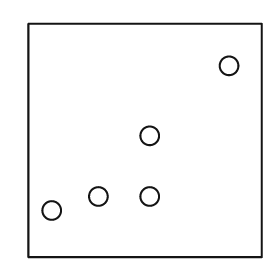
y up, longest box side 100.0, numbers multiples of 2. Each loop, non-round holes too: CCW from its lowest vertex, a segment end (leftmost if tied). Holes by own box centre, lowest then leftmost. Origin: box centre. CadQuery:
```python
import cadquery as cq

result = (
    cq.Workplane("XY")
    .moveTo(-50.0, -50.0)
    .lineTo(50.0, -50.0)
    .lineTo(50.0, 50.0)
    .lineTo(-50.0, 50.0)
    .close()
    .moveTo(-40.0, -30.0)
    .circle(4.0)
    .moveTo(-20.0, -24.0)
    .circle(4.0)
    .moveTo(2.0, -24.0)
    .circle(4.0)
    .moveTo(2.0, 2.0)
    .circle(4.0)
    .moveTo(36.0, 32.0)
    .circle(4.0)
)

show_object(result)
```